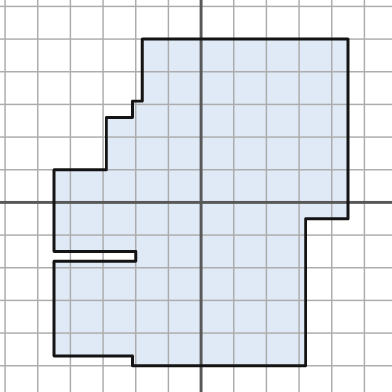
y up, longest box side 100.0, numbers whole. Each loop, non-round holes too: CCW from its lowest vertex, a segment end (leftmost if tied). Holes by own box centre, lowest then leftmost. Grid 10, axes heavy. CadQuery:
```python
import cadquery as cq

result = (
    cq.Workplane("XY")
    .moveTo(-21.0, -50.0)
    .lineTo(32.0, -50.0)
    .lineTo(32.0, -5.0)
    .lineTo(45.0, -5.0)
    .lineTo(45.0, 50.0)
    .lineTo(-18.0, 50.0)
    .lineTo(-18.0, 31.0)
    .lineTo(-21.0, 31.0)
    .lineTo(-21.0, 26.0)
    .lineTo(-29.0, 26.0)
    .lineTo(-29.0, 10.0)
    .lineTo(-45.0, 10.0)
    .lineTo(-45.0, -15.0)
    .lineTo(-20.0, -15.0)
    .lineTo(-20.0, -18.0)
    .lineTo(-45.0, -18.0)
    .lineTo(-45.0, -47.0)
    .lineTo(-21.0, -47.0)
    .close()
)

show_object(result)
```